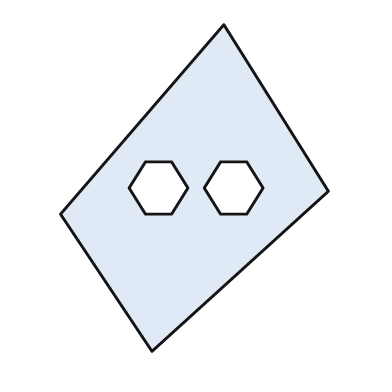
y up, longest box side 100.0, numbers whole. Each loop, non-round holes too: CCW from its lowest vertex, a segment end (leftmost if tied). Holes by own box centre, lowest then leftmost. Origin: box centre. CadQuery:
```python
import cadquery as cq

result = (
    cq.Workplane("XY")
    .moveTo(-13.0, -50.0)
    .lineTo(41.0, -1.0)
    .lineTo(9.0, 50.0)
    .lineTo(-41.0, -8.0)
    .close()
    .moveTo(-15.0, -8.0)
    .lineTo(-7.0, -8.0)
    .lineTo(-2.0, 0.0)
    .lineTo(-7.0, 8.0)
    .lineTo(-15.0, 8.0)
    .lineTo(-20.0, 0.0)
    .close()
    .moveTo(8.0, -8.0)
    .lineTo(16.0, -8.0)
    .lineTo(21.0, 0.0)
    .lineTo(16.0, 8.0)
    .lineTo(8.0, 8.0)
    .lineTo(3.0, 0.0)
    .close()
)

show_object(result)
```